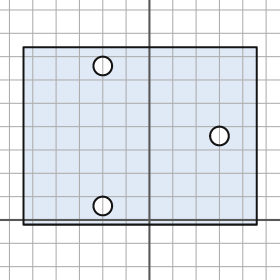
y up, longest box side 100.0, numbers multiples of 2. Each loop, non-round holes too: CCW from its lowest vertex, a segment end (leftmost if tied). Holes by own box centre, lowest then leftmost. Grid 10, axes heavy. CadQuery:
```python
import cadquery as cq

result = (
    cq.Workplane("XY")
    .moveTo(-54.0, -2.0)
    .lineTo(46.0, -2.0)
    .lineTo(46.0, 74.0)
    .lineTo(-54.0, 74.0)
    .close()
    .moveTo(-20.0, 6.0)
    .circle(4.0)
    .moveTo(30.0, 36.0)
    .circle(4.0)
    .moveTo(-20.0, 66.0)
    .circle(4.0)
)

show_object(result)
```